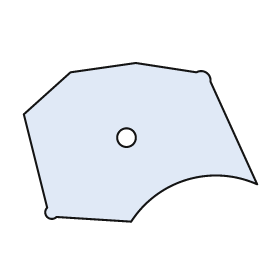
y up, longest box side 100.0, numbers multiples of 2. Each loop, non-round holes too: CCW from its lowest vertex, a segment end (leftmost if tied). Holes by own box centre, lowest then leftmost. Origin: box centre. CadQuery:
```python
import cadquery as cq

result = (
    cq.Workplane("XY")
    .moveTo(-4.0, -34.0)
    .threePointArc((20.0, -16.0), (50.0, -18.0))
    .lineTo(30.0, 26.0)
    .threePointArc((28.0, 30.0), (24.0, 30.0))
    .lineTo(-2.0, 34.0)
    .lineTo(-30.0, 30.0)
    .lineTo(-50.0, 12.0)
    .lineTo(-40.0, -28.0)
    .threePointArc((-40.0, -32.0), (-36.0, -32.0))
    .close()
    .moveTo(-6.0, 2.0)
    .circle(4.0)
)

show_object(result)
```